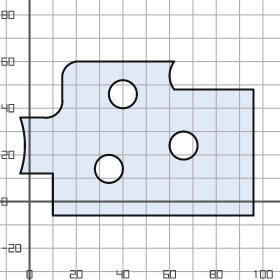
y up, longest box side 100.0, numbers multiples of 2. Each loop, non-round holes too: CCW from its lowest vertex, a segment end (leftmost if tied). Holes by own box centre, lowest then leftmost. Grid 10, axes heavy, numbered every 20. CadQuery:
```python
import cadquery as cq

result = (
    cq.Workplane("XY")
    .moveTo(10.0, -6.0)
    .lineTo(96.0, -6.0)
    .lineTo(96.0, 48.0)
    .lineTo(62.0, 48.0)
    .threePointArc((60.0, 54.0), (62.0, 60.0))
    .lineTo(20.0, 60.0)
    .threePointArc((16.0, 58.0), (14.0, 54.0))
    .lineTo(14.0, 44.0)
    .threePointArc((12.0, 38.0), (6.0, 36.0))
    .lineTo(-4.0, 36.0)
    .threePointArc((-2.0, 24.0), (-4.0, 12.0))
    .lineTo(10.0, 12.0)
    .close()
    .moveTo(34.0, 14.0)
    .circle(6.0)
    .moveTo(66.0, 24.0)
    .circle(6.0)
    .moveTo(40.0, 46.0)
    .circle(6.0)
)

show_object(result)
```